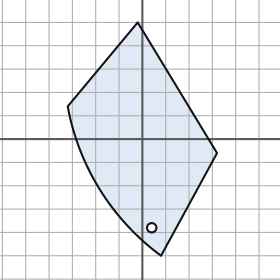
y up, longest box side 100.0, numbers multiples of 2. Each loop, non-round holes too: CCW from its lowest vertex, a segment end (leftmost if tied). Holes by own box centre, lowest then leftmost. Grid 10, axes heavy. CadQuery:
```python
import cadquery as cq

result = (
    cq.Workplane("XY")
    .moveTo(8.0, -50.0)
    .lineTo(32.0, -6.0)
    .lineTo(-2.0, 50.0)
    .lineTo(-32.0, 14.0)
    .threePointArc((-18.0, -22.0), (8.0, -50.0))
    .close()
    .moveTo(4.0, -38.0)
    .circle(2.0)
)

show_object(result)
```